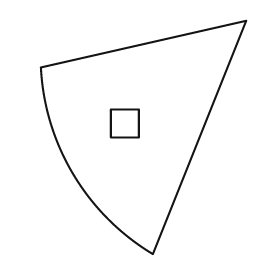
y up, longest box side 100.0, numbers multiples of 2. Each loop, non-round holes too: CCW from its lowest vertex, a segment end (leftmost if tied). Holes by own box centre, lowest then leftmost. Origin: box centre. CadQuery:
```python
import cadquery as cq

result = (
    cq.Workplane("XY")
    .moveTo(4.0, -50.0)
    .lineTo(44.0, 50.0)
    .lineTo(-44.0, 30.0)
    .threePointArc((-30.0, -16.0), (4.0, -50.0))
    .close()
    .moveTo(-14.0, 0.0)
    .lineTo(-2.0, 0.0)
    .lineTo(-2.0, 12.0)
    .lineTo(-14.0, 12.0)
    .close()
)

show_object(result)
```